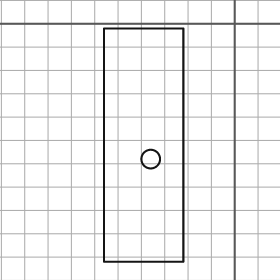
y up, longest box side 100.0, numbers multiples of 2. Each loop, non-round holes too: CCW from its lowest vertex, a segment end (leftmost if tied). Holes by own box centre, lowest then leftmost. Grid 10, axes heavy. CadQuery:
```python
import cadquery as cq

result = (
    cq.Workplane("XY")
    .moveTo(-56.0, -102.0)
    .lineTo(-22.0, -102.0)
    .lineTo(-22.0, -2.0)
    .lineTo(-56.0, -2.0)
    .close()
    .moveTo(-36.0, -58.0)
    .circle(4.0)
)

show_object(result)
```